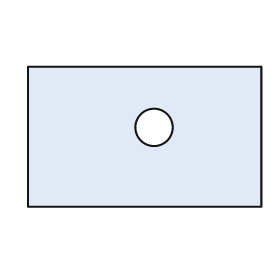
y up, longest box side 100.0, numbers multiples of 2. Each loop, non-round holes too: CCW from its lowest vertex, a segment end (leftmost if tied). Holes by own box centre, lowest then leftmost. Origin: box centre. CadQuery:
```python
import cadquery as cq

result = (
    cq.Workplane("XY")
    .moveTo(-50.0, -30.0)
    .lineTo(50.0, -30.0)
    .lineTo(50.0, 30.0)
    .lineTo(-50.0, 30.0)
    .close()
    .moveTo(4.0, 4.0)
    .circle(8.0)
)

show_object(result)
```